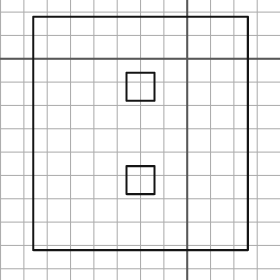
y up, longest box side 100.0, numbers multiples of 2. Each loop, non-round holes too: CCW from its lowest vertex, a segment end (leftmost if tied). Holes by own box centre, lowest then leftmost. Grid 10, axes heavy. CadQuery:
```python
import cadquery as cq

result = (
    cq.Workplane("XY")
    .moveTo(-66.0, -82.0)
    .lineTo(26.0, -82.0)
    .lineTo(26.0, 18.0)
    .lineTo(-66.0, 18.0)
    .close()
    .moveTo(-26.0, -58.0)
    .lineTo(-14.0, -58.0)
    .lineTo(-14.0, -46.0)
    .lineTo(-26.0, -46.0)
    .close()
    .moveTo(-26.0, -18.0)
    .lineTo(-14.0, -18.0)
    .lineTo(-14.0, -6.0)
    .lineTo(-26.0, -6.0)
    .close()
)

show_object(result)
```